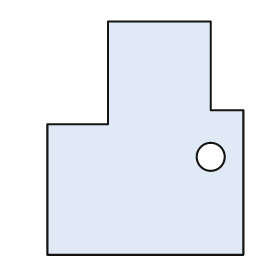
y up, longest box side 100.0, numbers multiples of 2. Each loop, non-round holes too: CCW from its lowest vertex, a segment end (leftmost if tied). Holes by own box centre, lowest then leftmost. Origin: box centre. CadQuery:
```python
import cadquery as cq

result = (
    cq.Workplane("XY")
    .moveTo(-42.0, -50.0)
    .lineTo(42.0, -50.0)
    .lineTo(42.0, 12.0)
    .lineTo(28.0, 12.0)
    .lineTo(28.0, 50.0)
    .lineTo(-16.0, 50.0)
    .lineTo(-16.0, 6.0)
    .lineTo(-42.0, 6.0)
    .close()
    .moveTo(28.0, -8.0)
    .circle(6.0)
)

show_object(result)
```